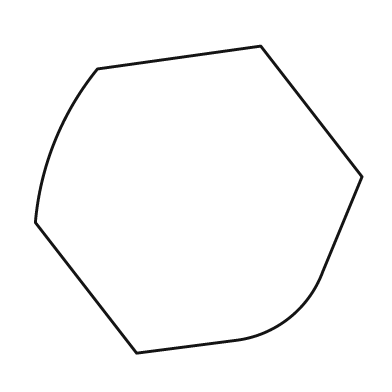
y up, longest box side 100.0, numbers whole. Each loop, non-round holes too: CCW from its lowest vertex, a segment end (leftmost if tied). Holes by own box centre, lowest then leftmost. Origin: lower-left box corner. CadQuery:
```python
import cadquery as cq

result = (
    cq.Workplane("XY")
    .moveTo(31.0, 0.0)
    .lineTo(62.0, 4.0)
    .threePointArc((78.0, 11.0), (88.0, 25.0))
    .lineTo(100.0, 54.0)
    .lineTo(69.0, 94.0)
    .lineTo(19.0, 87.0)
    .threePointArc((6.0, 65.0), (0.0, 40.0))
    .close()
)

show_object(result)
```